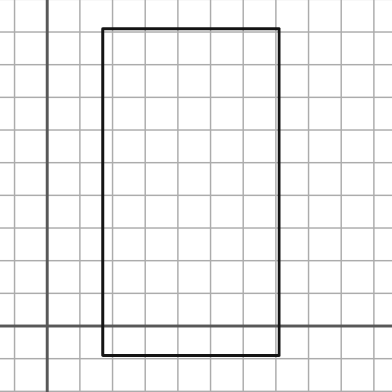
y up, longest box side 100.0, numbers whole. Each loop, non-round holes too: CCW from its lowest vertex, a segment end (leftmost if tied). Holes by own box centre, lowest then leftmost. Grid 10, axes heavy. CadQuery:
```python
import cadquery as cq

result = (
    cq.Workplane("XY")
    .moveTo(17.0, -9.0)
    .lineTo(71.0, -9.0)
    .lineTo(71.0, 91.0)
    .lineTo(17.0, 91.0)
    .close()
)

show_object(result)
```